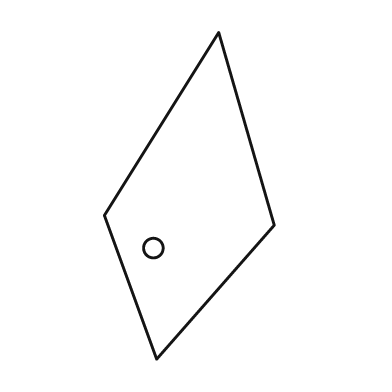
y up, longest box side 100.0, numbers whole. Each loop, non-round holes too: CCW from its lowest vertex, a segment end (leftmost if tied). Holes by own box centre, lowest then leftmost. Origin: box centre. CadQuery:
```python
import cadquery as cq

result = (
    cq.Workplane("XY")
    .moveTo(-10.0, -50.0)
    .lineTo(26.0, -9.0)
    .lineTo(9.0, 50.0)
    .lineTo(-26.0, -6.0)
    .close()
    .moveTo(-11.0, -16.0)
    .circle(3.0)
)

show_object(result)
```